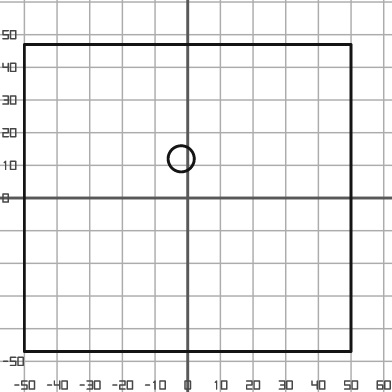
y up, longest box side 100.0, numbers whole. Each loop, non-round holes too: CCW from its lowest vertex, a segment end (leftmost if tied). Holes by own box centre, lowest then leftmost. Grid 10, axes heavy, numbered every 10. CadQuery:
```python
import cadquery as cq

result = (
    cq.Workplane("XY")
    .moveTo(-50.0, -47.0)
    .lineTo(50.0, -47.0)
    .lineTo(50.0, 47.0)
    .lineTo(-50.0, 47.0)
    .close()
    .moveTo(-2.0, 12.0)
    .circle(4.0)
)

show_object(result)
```